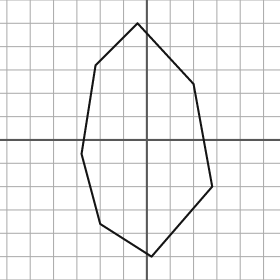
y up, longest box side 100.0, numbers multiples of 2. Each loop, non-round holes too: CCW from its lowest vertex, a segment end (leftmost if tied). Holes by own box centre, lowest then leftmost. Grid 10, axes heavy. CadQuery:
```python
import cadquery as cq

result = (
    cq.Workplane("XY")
    .moveTo(2.0, -50.0)
    .lineTo(28.0, -20.0)
    .lineTo(20.0, 24.0)
    .lineTo(-4.0, 50.0)
    .lineTo(-22.0, 32.0)
    .lineTo(-28.0, -6.0)
    .lineTo(-20.0, -36.0)
    .close()
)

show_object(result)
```